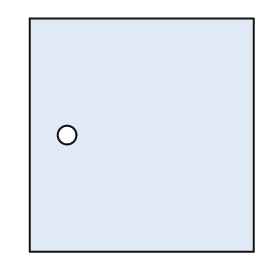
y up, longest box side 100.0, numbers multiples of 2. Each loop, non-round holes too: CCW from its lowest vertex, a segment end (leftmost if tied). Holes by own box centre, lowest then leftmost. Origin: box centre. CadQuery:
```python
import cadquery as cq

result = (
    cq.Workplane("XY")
    .moveTo(-48.0, -50.0)
    .lineTo(48.0, -50.0)
    .lineTo(48.0, 50.0)
    .lineTo(-48.0, 50.0)
    .close()
    .moveTo(-32.0, 0.0)
    .circle(4.0)
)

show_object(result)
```